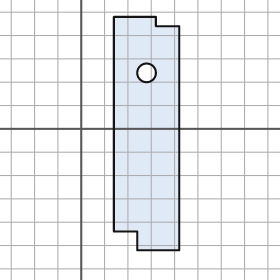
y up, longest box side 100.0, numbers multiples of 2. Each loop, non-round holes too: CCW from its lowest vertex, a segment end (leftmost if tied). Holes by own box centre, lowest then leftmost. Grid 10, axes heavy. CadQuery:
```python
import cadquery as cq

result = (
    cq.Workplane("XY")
    .moveTo(24.0, -52.0)
    .lineTo(42.0, -52.0)
    .lineTo(42.0, 44.0)
    .lineTo(32.0, 44.0)
    .lineTo(32.0, 48.0)
    .lineTo(14.0, 48.0)
    .lineTo(14.0, -44.0)
    .lineTo(24.0, -44.0)
    .close()
    .moveTo(28.0, 24.0)
    .circle(4.0)
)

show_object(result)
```